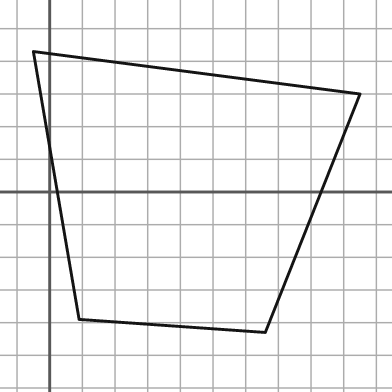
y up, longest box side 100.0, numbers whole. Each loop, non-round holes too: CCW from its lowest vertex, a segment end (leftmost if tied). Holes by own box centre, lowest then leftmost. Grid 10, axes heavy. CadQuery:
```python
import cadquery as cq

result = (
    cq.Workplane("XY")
    .moveTo(66.0, -43.0)
    .lineTo(95.0, 30.0)
    .lineTo(-5.0, 43.0)
    .lineTo(9.0, -39.0)
    .close()
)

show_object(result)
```